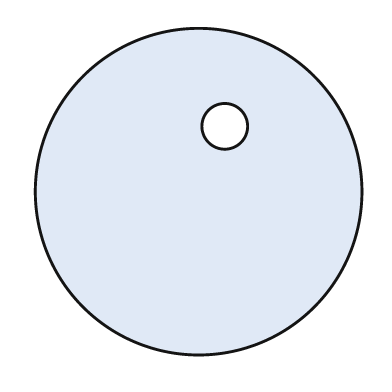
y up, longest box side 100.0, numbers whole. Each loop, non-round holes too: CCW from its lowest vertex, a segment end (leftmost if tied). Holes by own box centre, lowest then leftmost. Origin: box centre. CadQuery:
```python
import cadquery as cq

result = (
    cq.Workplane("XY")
    .moveTo(0.0, 0.0)
    .circle(50.0)
    .moveTo(8.0, 20.0)
    .circle(7.0)
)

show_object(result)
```